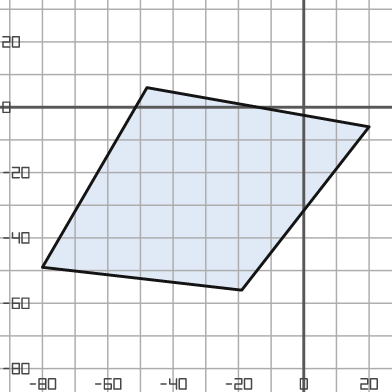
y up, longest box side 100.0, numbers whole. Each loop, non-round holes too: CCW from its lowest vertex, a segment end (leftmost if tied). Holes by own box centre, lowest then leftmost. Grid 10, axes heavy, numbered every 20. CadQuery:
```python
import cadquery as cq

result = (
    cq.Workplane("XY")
    .moveTo(-19.0, -56.0)
    .lineTo(20.0, -6.0)
    .lineTo(-48.0, 6.0)
    .lineTo(-80.0, -49.0)
    .close()
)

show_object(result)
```